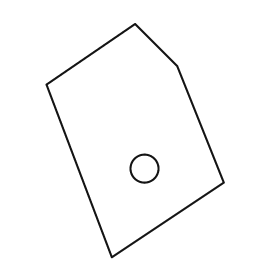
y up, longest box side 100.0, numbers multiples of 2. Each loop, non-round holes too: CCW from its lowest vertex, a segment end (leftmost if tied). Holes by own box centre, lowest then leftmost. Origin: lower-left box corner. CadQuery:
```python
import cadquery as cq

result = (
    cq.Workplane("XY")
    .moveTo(28.0, 0.0)
    .lineTo(76.0, 32.0)
    .lineTo(56.0, 82.0)
    .lineTo(38.0, 100.0)
    .lineTo(0.0, 74.0)
    .close()
    .moveTo(42.0, 38.0)
    .circle(6.0)
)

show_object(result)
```